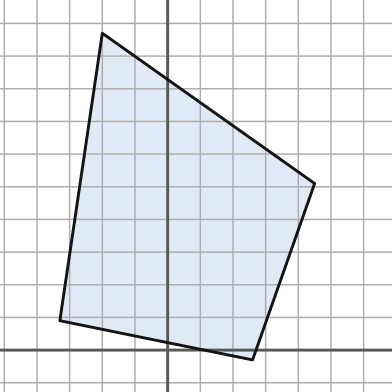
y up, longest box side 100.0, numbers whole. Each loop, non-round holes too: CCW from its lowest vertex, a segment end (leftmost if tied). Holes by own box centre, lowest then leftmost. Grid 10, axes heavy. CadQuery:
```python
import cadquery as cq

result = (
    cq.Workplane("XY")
    .moveTo(26.0, -3.0)
    .lineTo(45.0, 51.0)
    .lineTo(-20.0, 97.0)
    .lineTo(-33.0, 9.0)
    .close()
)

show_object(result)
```